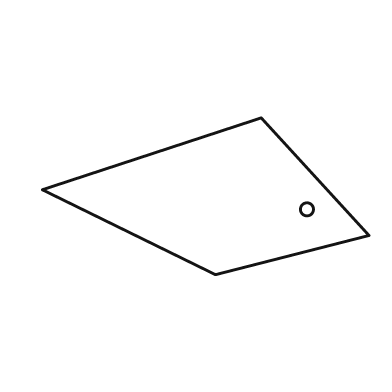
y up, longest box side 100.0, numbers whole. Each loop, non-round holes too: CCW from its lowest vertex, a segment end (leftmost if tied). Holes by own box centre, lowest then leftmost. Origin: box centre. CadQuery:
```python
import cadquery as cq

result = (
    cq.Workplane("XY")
    .moveTo(3.0, -24.0)
    .lineTo(50.0, -12.0)
    .lineTo(17.0, 24.0)
    .lineTo(-50.0, 2.0)
    .close()
    .moveTo(31.0, -4.0)
    .circle(2.0)
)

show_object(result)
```